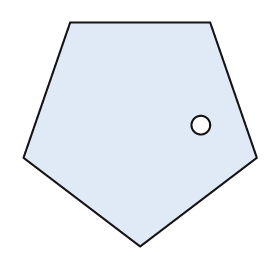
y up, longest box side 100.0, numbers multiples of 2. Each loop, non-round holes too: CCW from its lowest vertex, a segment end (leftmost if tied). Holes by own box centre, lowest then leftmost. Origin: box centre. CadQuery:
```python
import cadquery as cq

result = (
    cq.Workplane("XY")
    .moveTo(0.0, -48.0)
    .lineTo(50.0, -10.0)
    .lineTo(30.0, 48.0)
    .lineTo(-30.0, 48.0)
    .lineTo(-50.0, -10.0)
    .close()
    .moveTo(26.0, 4.0)
    .circle(4.0)
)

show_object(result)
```